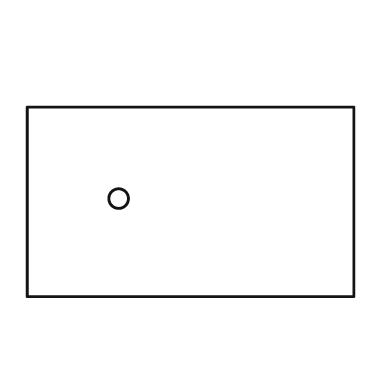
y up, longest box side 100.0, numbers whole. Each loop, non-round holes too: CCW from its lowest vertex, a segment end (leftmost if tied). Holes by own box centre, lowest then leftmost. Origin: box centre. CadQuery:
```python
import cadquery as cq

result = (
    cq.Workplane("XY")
    .moveTo(-50.0, -29.0)
    .lineTo(50.0, -29.0)
    .lineTo(50.0, 29.0)
    .lineTo(-50.0, 29.0)
    .close()
    .moveTo(-22.0, 1.0)
    .circle(3.0)
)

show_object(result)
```